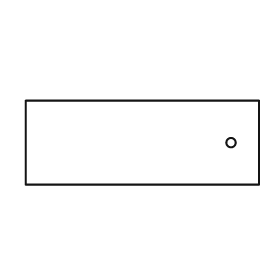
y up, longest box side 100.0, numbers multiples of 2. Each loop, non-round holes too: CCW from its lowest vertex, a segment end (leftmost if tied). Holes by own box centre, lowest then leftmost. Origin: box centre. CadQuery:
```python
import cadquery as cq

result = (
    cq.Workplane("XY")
    .moveTo(-50.0, -18.0)
    .lineTo(50.0, -18.0)
    .lineTo(50.0, 18.0)
    .lineTo(-50.0, 18.0)
    .close()
    .moveTo(38.0, 0.0)
    .circle(2.0)
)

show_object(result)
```